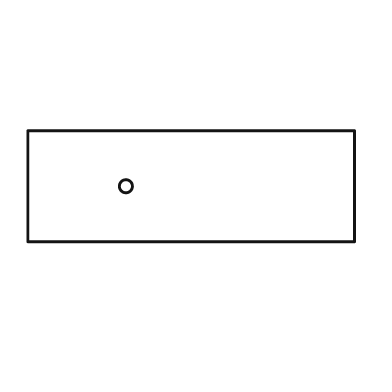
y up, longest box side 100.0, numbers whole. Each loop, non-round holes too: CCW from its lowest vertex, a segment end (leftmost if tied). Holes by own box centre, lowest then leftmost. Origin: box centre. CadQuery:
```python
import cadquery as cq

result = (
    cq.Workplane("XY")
    .moveTo(-50.0, -17.0)
    .lineTo(50.0, -17.0)
    .lineTo(50.0, 17.0)
    .lineTo(-50.0, 17.0)
    .close()
    .moveTo(-20.0, 0.0)
    .circle(2.0)
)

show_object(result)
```